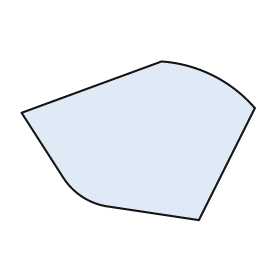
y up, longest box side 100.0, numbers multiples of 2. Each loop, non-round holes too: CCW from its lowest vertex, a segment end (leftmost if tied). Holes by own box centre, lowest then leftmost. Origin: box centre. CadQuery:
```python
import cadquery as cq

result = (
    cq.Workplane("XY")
    .moveTo(26.0, -34.0)
    .lineTo(50.0, 14.0)
    .threePointArc((32.0, 28.0), (10.0, 34.0))
    .lineTo(-50.0, 12.0)
    .lineTo(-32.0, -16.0)
    .threePointArc((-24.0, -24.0), (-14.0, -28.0))
    .close()
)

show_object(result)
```